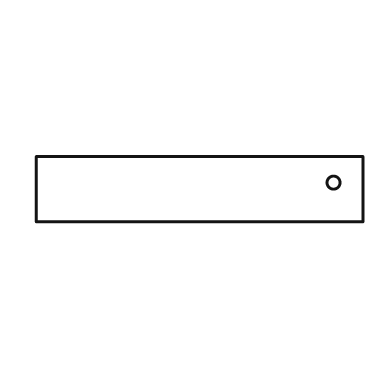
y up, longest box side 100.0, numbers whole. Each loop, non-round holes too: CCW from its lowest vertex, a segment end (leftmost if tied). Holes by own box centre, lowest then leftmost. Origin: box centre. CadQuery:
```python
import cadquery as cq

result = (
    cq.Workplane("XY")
    .moveTo(-50.0, -10.0)
    .lineTo(50.0, -10.0)
    .lineTo(50.0, 10.0)
    .lineTo(-50.0, 10.0)
    .close()
    .moveTo(41.0, 2.0)
    .circle(2.0)
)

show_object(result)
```